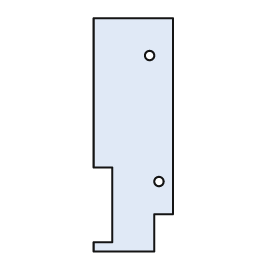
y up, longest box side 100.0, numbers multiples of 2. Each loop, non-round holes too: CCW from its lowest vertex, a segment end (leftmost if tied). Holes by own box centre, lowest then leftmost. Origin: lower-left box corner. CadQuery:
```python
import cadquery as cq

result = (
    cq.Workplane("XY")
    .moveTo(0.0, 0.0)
    .lineTo(26.0, 0.0)
    .lineTo(26.0, 16.0)
    .lineTo(34.0, 16.0)
    .lineTo(34.0, 100.0)
    .lineTo(0.0, 100.0)
    .lineTo(0.0, 36.0)
    .lineTo(8.0, 36.0)
    .lineTo(8.0, 4.0)
    .lineTo(0.0, 4.0)
    .close()
    .moveTo(28.0, 30.0)
    .circle(2.0)
    .moveTo(24.0, 84.0)
    .circle(2.0)
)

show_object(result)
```